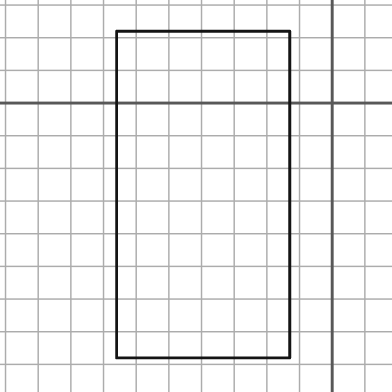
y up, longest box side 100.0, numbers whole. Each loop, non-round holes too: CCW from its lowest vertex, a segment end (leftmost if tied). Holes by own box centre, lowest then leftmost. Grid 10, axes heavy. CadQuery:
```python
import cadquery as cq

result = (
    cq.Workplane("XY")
    .moveTo(-66.0, -78.0)
    .lineTo(-13.0, -78.0)
    .lineTo(-13.0, 22.0)
    .lineTo(-66.0, 22.0)
    .close()
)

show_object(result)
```